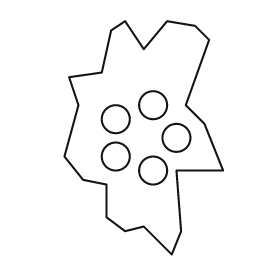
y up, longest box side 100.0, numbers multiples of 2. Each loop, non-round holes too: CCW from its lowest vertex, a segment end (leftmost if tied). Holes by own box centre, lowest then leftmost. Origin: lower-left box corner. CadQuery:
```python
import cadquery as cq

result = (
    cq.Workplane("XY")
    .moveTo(46.0, 0.0)
    .lineTo(50.0, 10.0)
    .lineTo(48.0, 36.0)
    .lineTo(68.0, 36.0)
    .lineTo(60.0, 56.0)
    .lineTo(52.0, 64.0)
    .lineTo(62.0, 92.0)
    .lineTo(56.0, 98.0)
    .lineTo(44.0, 100.0)
    .lineTo(34.0, 88.0)
    .lineTo(26.0, 100.0)
    .lineTo(20.0, 96.0)
    .lineTo(16.0, 78.0)
    .lineTo(2.0, 76.0)
    .lineTo(6.0, 64.0)
    .lineTo(0.0, 42.0)
    .lineTo(8.0, 32.0)
    .lineTo(18.0, 30.0)
    .lineTo(18.0, 16.0)
    .lineTo(26.0, 10.0)
    .lineTo(34.0, 12.0)
    .close()
    .moveTo(38.0, 36.0)
    .circle(6.0)
    .moveTo(22.0, 42.0)
    .circle(6.0)
    .moveTo(48.0, 50.0)
    .circle(6.0)
    .moveTo(22.0, 58.0)
    .circle(6.0)
    .moveTo(38.0, 64.0)
    .circle(6.0)
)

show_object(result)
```